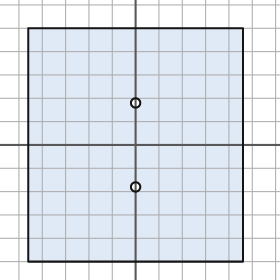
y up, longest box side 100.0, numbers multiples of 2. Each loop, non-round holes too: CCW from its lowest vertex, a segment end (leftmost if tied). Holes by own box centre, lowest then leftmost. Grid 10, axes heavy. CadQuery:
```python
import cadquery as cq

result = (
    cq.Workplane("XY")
    .moveTo(-46.0, -50.0)
    .lineTo(46.0, -50.0)
    .lineTo(46.0, 50.0)
    .lineTo(-46.0, 50.0)
    .close()
    .moveTo(0.0, -18.0)
    .circle(2.0)
    .moveTo(0.0, 18.0)
    .circle(2.0)
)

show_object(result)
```